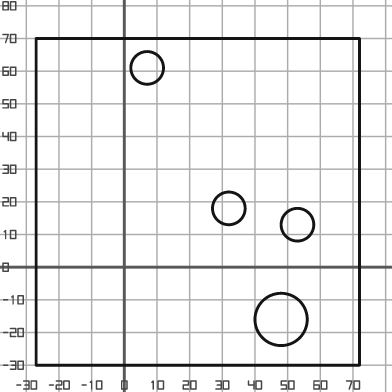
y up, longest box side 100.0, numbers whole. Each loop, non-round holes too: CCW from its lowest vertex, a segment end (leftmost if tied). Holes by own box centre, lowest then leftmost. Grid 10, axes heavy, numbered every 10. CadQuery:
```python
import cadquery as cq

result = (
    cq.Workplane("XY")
    .moveTo(-27.0, -30.0)
    .lineTo(72.0, -30.0)
    .lineTo(72.0, 70.0)
    .lineTo(-27.0, 70.0)
    .close()
    .moveTo(48.0, -16.0)
    .circle(8.0)
    .moveTo(53.0, 13.0)
    .circle(5.0)
    .moveTo(32.0, 18.0)
    .circle(5.0)
    .moveTo(7.0, 61.0)
    .circle(5.0)
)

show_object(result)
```